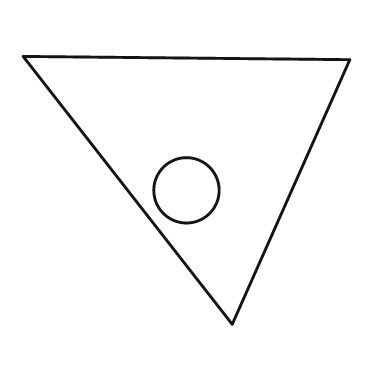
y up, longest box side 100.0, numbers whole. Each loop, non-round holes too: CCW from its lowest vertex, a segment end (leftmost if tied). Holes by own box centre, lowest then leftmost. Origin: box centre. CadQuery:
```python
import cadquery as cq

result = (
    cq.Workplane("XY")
    .moveTo(14.0, -41.0)
    .lineTo(50.0, 40.0)
    .lineTo(-50.0, 41.0)
    .close()
    .moveTo(0.0, 0.0)
    .circle(10.0)
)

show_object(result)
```